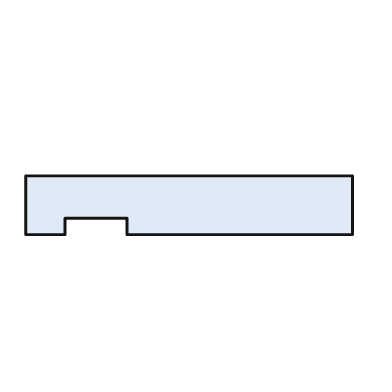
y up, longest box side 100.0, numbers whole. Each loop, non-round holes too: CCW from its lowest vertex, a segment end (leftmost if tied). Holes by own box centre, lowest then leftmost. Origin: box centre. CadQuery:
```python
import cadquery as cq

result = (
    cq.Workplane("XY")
    .moveTo(-50.0, -9.0)
    .lineTo(-38.0, -9.0)
    .lineTo(-38.0, -4.0)
    .lineTo(-19.0, -4.0)
    .lineTo(-19.0, -9.0)
    .lineTo(50.0, -9.0)
    .lineTo(50.0, 9.0)
    .lineTo(-50.0, 9.0)
    .close()
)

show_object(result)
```